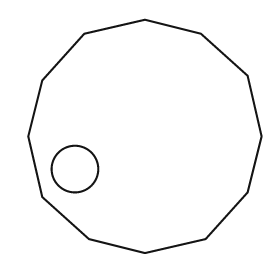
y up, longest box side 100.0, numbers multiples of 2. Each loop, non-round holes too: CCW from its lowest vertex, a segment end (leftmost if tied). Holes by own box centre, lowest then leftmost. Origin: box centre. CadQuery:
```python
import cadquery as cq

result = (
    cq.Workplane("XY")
    .moveTo(0.0, -50.0)
    .lineTo(26.0, -44.0)
    .lineTo(44.0, -24.0)
    .lineTo(50.0, 0.0)
    .lineTo(44.0, 26.0)
    .lineTo(24.0, 44.0)
    .lineTo(0.0, 50.0)
    .lineTo(-26.0, 44.0)
    .lineTo(-44.0, 24.0)
    .lineTo(-50.0, 0.0)
    .lineTo(-44.0, -26.0)
    .lineTo(-24.0, -44.0)
    .close()
    .moveTo(-30.0, -14.0)
    .circle(10.0)
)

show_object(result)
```